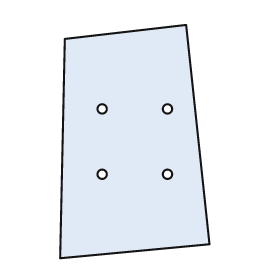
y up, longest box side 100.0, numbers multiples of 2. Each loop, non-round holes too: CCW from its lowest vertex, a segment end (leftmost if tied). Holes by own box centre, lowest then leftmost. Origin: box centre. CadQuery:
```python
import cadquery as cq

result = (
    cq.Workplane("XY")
    .moveTo(-32.0, -50.0)
    .lineTo(32.0, -44.0)
    .lineTo(22.0, 50.0)
    .lineTo(-30.0, 44.0)
    .close()
    .moveTo(-14.0, -14.0)
    .circle(2.0)
    .moveTo(14.0, -14.0)
    .circle(2.0)
    .moveTo(-14.0, 14.0)
    .circle(2.0)
    .moveTo(14.0, 14.0)
    .circle(2.0)
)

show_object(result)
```